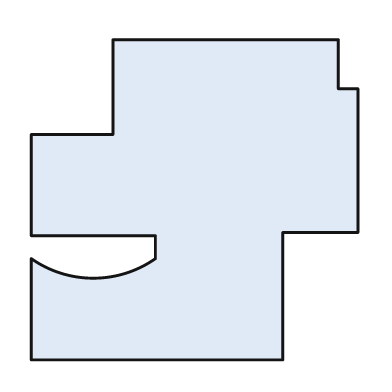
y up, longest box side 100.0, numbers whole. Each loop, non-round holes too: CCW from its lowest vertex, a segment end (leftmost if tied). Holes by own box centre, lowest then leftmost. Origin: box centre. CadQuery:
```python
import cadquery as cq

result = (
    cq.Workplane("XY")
    .moveTo(-50.0, -49.0)
    .lineTo(27.0, -49.0)
    .lineTo(27.0, -10.0)
    .lineTo(50.0, -10.0)
    .lineTo(50.0, 34.0)
    .lineTo(44.0, 34.0)
    .lineTo(44.0, 49.0)
    .lineTo(-25.0, 49.0)
    .lineTo(-25.0, 20.0)
    .lineTo(-50.0, 20.0)
    .lineTo(-50.0, -11.0)
    .lineTo(-12.0, -11.0)
    .lineTo(-12.0, -18.0)
    .threePointArc((-31.0, -24.0), (-50.0, -18.0))
    .close()
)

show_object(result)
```